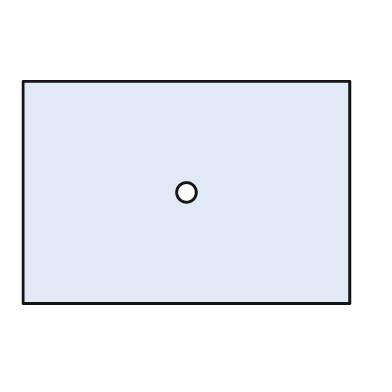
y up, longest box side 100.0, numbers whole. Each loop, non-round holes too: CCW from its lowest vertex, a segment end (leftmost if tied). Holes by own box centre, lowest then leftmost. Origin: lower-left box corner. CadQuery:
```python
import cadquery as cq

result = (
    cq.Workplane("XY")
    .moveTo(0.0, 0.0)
    .lineTo(100.0, 0.0)
    .lineTo(100.0, 68.0)
    .lineTo(0.0, 68.0)
    .close()
    .moveTo(50.0, 34.0)
    .circle(3.0)
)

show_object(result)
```